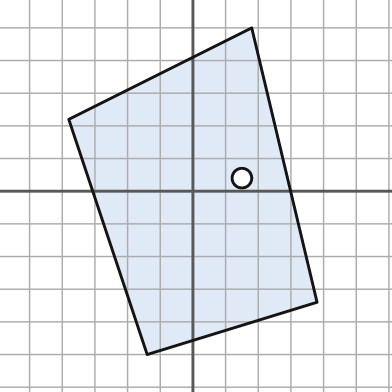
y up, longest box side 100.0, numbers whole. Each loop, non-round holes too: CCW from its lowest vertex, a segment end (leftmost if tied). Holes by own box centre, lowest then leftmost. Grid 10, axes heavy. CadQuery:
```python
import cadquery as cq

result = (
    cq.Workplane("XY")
    .moveTo(-14.0, -50.0)
    .lineTo(38.0, -34.0)
    .lineTo(18.0, 50.0)
    .lineTo(-38.0, 22.0)
    .close()
    .moveTo(15.0, 4.0)
    .circle(3.0)
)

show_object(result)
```